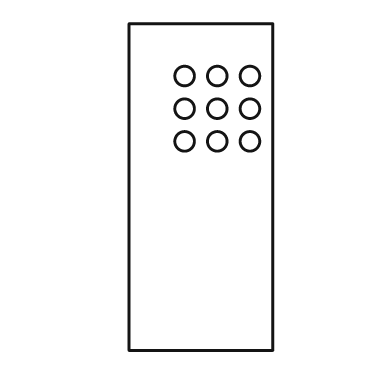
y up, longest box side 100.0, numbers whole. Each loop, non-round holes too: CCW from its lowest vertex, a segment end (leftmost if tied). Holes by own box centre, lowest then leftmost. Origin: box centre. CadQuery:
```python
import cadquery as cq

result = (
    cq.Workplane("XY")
    .moveTo(-22.0, -50.0)
    .lineTo(22.0, -50.0)
    .lineTo(22.0, 50.0)
    .lineTo(-22.0, 50.0)
    .close()
    .moveTo(-5.0, 14.0)
    .circle(3.0)
    .moveTo(5.0, 14.0)
    .circle(3.0)
    .moveTo(15.0, 14.0)
    .circle(3.0)
    .moveTo(-5.0, 24.0)
    .circle(3.0)
    .moveTo(5.0, 24.0)
    .circle(3.0)
    .moveTo(15.0, 24.0)
    .circle(3.0)
    .moveTo(-5.0, 34.0)
    .circle(3.0)
    .moveTo(5.0, 34.0)
    .circle(3.0)
    .moveTo(15.0, 34.0)
    .circle(3.0)
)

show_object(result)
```